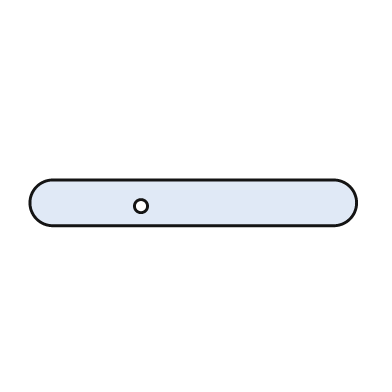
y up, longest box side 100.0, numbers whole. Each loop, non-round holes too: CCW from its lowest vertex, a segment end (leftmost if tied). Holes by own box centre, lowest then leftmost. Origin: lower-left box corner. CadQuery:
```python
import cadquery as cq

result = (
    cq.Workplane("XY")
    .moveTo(7.0, 0.0)
    .lineTo(93.0, 0.0)
    .threePointArc((100.0, 7.0), (93.0, 14.0))
    .lineTo(7.0, 14.0)
    .threePointArc((0.0, 7.0), (7.0, 0.0))
    .close()
    .moveTo(34.0, 6.0)
    .circle(2.0)
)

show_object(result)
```